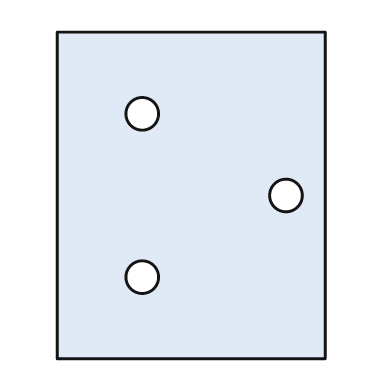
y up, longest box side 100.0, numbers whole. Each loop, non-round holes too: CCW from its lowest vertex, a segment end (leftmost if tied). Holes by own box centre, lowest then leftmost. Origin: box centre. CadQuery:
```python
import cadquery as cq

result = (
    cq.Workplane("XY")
    .moveTo(-41.0, -50.0)
    .lineTo(41.0, -50.0)
    .lineTo(41.0, 50.0)
    .lineTo(-41.0, 50.0)
    .close()
    .moveTo(-15.0, -25.0)
    .circle(5.0)
    .moveTo(29.0, 0.0)
    .circle(5.0)
    .moveTo(-15.0, 25.0)
    .circle(5.0)
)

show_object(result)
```